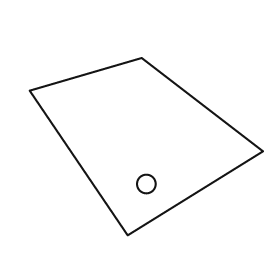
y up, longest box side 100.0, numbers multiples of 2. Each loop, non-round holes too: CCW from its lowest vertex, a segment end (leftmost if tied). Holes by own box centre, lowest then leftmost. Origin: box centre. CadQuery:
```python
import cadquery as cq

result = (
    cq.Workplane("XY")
    .moveTo(-8.0, -38.0)
    .lineTo(50.0, -2.0)
    .lineTo(-2.0, 38.0)
    .lineTo(-50.0, 24.0)
    .close()
    .moveTo(0.0, -16.0)
    .circle(4.0)
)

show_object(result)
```